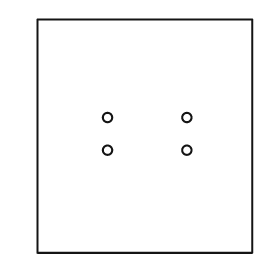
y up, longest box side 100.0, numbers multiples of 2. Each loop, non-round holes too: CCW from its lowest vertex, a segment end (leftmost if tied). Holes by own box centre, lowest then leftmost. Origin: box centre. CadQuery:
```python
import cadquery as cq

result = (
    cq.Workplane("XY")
    .moveTo(-46.0, -50.0)
    .lineTo(46.0, -50.0)
    .lineTo(46.0, 50.0)
    .lineTo(-46.0, 50.0)
    .close()
    .moveTo(-16.0, -6.0)
    .circle(2.0)
    .moveTo(18.0, -6.0)
    .circle(2.0)
    .moveTo(-16.0, 8.0)
    .circle(2.0)
    .moveTo(18.0, 8.0)
    .circle(2.0)
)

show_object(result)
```